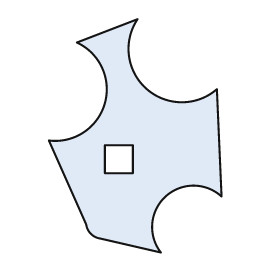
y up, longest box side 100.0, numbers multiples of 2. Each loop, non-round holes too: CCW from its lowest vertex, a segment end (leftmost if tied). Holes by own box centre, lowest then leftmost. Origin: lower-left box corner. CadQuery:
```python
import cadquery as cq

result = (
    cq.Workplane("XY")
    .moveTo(48.0, 0.0)
    .threePointArc((50.0, 24.0), (74.0, 24.0))
    .lineTo(72.0, 70.0)
    .threePointArc((42.0, 70.0), (38.0, 100.0))
    .lineTo(12.0, 90.0)
    .threePointArc((24.0, 64.0), (0.0, 48.0))
    .lineTo(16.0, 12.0)
    .threePointArc((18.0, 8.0), (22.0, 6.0))
    .close()
    .moveTo(24.0, 34.0)
    .lineTo(36.0, 34.0)
    .lineTo(36.0, 46.0)
    .lineTo(24.0, 46.0)
    .close()
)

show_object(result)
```